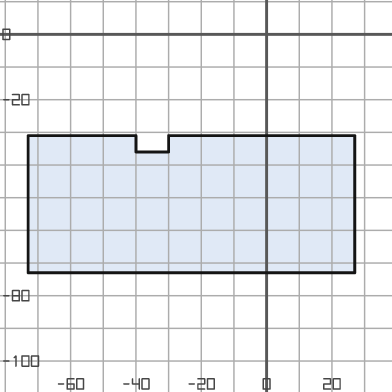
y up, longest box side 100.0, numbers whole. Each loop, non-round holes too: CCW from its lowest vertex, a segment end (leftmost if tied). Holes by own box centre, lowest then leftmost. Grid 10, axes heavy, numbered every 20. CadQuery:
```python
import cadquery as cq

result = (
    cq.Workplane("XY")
    .moveTo(-73.0, -73.0)
    .lineTo(27.0, -73.0)
    .lineTo(27.0, -31.0)
    .lineTo(-30.0, -31.0)
    .lineTo(-30.0, -36.0)
    .lineTo(-40.0, -36.0)
    .lineTo(-40.0, -31.0)
    .lineTo(-73.0, -31.0)
    .close()
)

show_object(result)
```